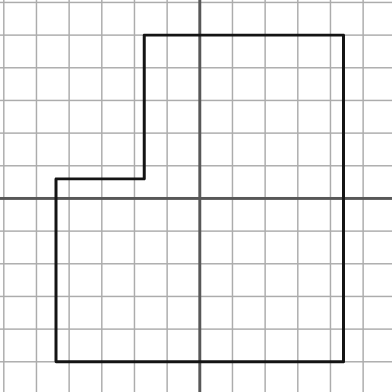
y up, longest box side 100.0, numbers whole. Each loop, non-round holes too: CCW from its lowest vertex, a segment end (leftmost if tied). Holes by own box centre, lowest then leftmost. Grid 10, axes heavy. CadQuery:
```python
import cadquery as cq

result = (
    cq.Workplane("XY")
    .moveTo(-44.0, -50.0)
    .lineTo(44.0, -50.0)
    .lineTo(44.0, 50.0)
    .lineTo(-17.0, 50.0)
    .lineTo(-17.0, 6.0)
    .lineTo(-44.0, 6.0)
    .close()
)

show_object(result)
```